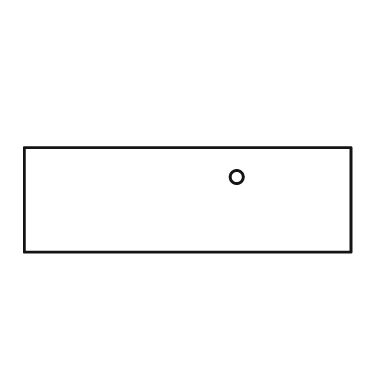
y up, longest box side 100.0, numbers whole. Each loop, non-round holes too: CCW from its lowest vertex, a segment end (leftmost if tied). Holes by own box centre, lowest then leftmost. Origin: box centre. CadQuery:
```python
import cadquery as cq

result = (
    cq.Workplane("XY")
    .moveTo(-50.0, -16.0)
    .lineTo(50.0, -16.0)
    .lineTo(50.0, 16.0)
    .lineTo(-50.0, 16.0)
    .close()
    .moveTo(15.0, 7.0)
    .circle(2.0)
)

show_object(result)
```